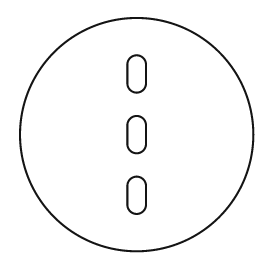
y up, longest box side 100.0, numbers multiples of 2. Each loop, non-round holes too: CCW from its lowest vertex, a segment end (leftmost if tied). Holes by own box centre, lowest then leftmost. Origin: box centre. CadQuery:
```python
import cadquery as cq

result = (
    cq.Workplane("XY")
    .moveTo(0.0, 0.0)
    .circle(50.0)
    .moveTo(-4.0, -30.0)
    .threePointArc((0.0, -34.0), (4.0, -30.0))
    .lineTo(4.0, -22.0)
    .threePointArc((0.0, -18.0), (-4.0, -22.0))
    .close()
    .moveTo(-4.0, -4.0)
    .threePointArc((0.0, -8.0), (4.0, -4.0))
    .lineTo(4.0, 4.0)
    .threePointArc((0.0, 8.0), (-4.0, 4.0))
    .close()
    .moveTo(-4.0, 22.0)
    .threePointArc((0.0, 18.0), (4.0, 22.0))
    .lineTo(4.0, 30.0)
    .threePointArc((0.0, 34.0), (-4.0, 30.0))
    .close()
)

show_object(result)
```